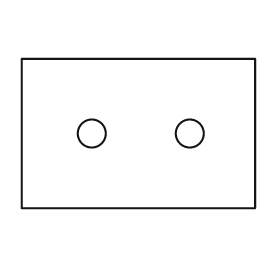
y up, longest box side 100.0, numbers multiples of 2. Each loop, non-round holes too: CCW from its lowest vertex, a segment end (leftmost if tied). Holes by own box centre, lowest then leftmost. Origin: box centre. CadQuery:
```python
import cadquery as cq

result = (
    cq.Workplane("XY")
    .moveTo(-50.0, -32.0)
    .lineTo(50.0, -32.0)
    .lineTo(50.0, 32.0)
    .lineTo(-50.0, 32.0)
    .close()
    .moveTo(-20.0, 0.0)
    .circle(6.0)
    .moveTo(22.0, 0.0)
    .circle(6.0)
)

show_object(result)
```